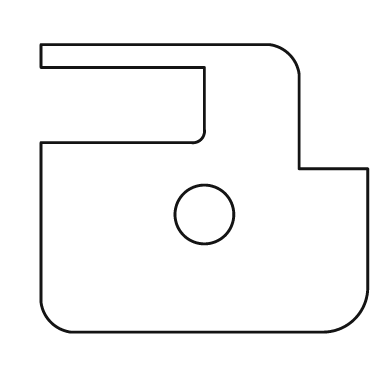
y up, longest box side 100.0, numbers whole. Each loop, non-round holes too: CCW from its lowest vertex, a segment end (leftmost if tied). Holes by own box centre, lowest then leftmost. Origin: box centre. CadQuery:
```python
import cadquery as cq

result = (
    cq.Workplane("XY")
    .moveTo(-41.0, -44.0)
    .lineTo(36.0, -44.0)
    .threePointArc((46.0, -40.0), (50.0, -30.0))
    .lineTo(50.0, 6.0)
    .lineTo(29.0, 6.0)
    .lineTo(29.0, 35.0)
    .threePointArc((26.0, 41.0), (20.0, 44.0))
    .lineTo(-50.0, 44.0)
    .lineTo(-50.0, 37.0)
    .lineTo(0.0, 37.0)
    .lineTo(0.0, 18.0)
    .threePointArc((-1.0, 15.0), (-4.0, 14.0))
    .lineTo(-50.0, 14.0)
    .lineTo(-50.0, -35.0)
    .threePointArc((-47.0, -41.0), (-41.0, -44.0))
    .close()
    .moveTo(0.0, -8.0)
    .circle(9.0)
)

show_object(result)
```